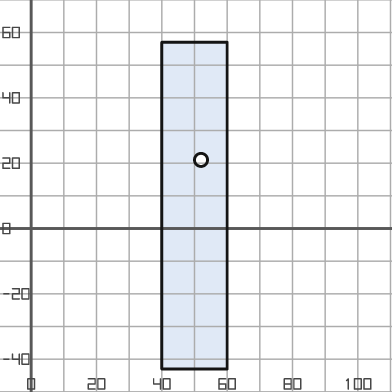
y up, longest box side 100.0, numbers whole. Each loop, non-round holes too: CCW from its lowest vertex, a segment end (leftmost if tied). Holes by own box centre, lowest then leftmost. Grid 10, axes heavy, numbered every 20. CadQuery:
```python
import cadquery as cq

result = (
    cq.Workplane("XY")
    .moveTo(40.0, -43.0)
    .lineTo(60.0, -43.0)
    .lineTo(60.0, 57.0)
    .lineTo(40.0, 57.0)
    .close()
    .moveTo(52.0, 21.0)
    .circle(2.0)
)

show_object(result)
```